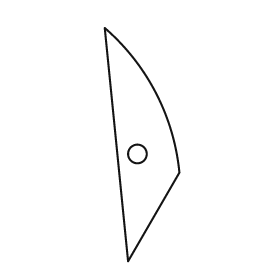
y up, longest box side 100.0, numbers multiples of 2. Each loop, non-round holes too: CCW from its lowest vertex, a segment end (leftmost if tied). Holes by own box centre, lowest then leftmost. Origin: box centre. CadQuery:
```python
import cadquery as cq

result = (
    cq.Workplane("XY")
    .moveTo(-6.0, -50.0)
    .lineTo(16.0, -12.0)
    .threePointArc((6.0, 22.0), (-16.0, 50.0))
    .close()
    .moveTo(-2.0, -4.0)
    .circle(4.0)
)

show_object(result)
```